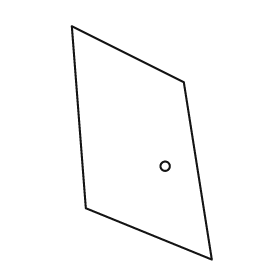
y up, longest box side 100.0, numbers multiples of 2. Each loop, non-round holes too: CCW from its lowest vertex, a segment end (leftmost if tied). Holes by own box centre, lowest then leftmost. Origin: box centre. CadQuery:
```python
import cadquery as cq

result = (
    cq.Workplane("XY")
    .moveTo(30.0, -50.0)
    .lineTo(18.0, 26.0)
    .lineTo(-30.0, 50.0)
    .lineTo(-24.0, -28.0)
    .close()
    .moveTo(10.0, -10.0)
    .circle(2.0)
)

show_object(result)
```